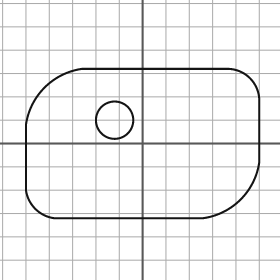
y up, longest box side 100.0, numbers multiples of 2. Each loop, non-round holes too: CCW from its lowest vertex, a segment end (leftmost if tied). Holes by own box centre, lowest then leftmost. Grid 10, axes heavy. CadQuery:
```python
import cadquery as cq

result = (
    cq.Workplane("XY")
    .moveTo(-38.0, -32.0)
    .lineTo(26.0, -32.0)
    .threePointArc((42.0, -24.0), (50.0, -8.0))
    .lineTo(50.0, 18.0)
    .threePointArc((46.0, 28.0), (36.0, 32.0))
    .lineTo(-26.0, 32.0)
    .threePointArc((-42.0, 24.0), (-50.0, 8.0))
    .lineTo(-50.0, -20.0)
    .threePointArc((-46.0, -28.0), (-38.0, -32.0))
    .close()
    .moveTo(-12.0, 10.0)
    .circle(8.0)
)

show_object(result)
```